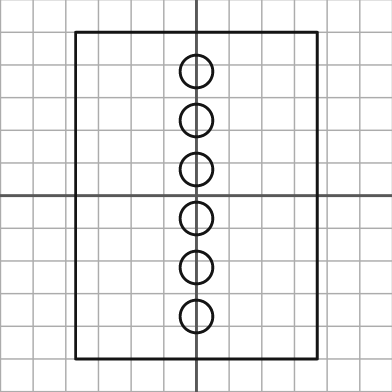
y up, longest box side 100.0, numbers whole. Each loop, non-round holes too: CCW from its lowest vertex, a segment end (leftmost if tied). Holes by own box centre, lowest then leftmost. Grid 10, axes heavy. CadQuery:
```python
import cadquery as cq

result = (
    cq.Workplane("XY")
    .moveTo(-37.0, -50.0)
    .lineTo(37.0, -50.0)
    .lineTo(37.0, 50.0)
    .lineTo(-37.0, 50.0)
    .close()
    .moveTo(0.0, -37.0)
    .circle(5.0)
    .moveTo(0.0, -22.0)
    .circle(5.0)
    .moveTo(0.0, -7.0)
    .circle(5.0)
    .moveTo(0.0, 8.0)
    .circle(5.0)
    .moveTo(0.0, 23.0)
    .circle(5.0)
    .moveTo(0.0, 38.0)
    .circle(5.0)
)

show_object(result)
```